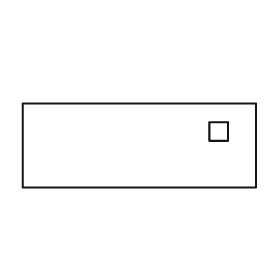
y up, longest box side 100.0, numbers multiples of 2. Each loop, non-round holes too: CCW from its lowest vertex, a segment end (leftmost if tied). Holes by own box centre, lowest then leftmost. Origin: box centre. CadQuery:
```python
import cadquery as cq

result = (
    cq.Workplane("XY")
    .moveTo(-50.0, -18.0)
    .lineTo(50.0, -18.0)
    .lineTo(50.0, 18.0)
    .lineTo(-50.0, 18.0)
    .close()
    .moveTo(30.0, 2.0)
    .lineTo(38.0, 2.0)
    .lineTo(38.0, 10.0)
    .lineTo(30.0, 10.0)
    .close()
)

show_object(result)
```